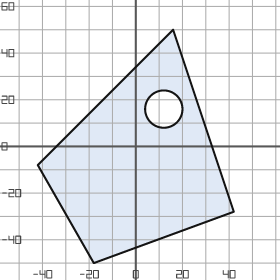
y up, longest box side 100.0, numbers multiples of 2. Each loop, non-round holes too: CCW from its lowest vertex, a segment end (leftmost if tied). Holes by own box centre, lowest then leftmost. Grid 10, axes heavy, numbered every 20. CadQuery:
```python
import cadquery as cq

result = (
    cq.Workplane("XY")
    .moveTo(-18.0, -50.0)
    .lineTo(42.0, -28.0)
    .lineTo(16.0, 50.0)
    .lineTo(-42.0, -8.0)
    .close()
    .moveTo(12.0, 16.0)
    .circle(8.0)
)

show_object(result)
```